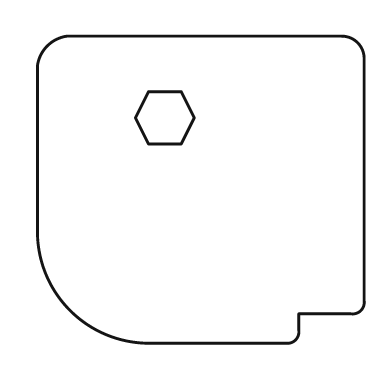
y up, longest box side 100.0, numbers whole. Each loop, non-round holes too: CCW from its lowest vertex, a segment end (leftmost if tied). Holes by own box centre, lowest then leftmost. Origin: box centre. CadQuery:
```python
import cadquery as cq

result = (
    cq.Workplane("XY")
    .moveTo(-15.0, -47.0)
    .lineTo(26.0, -47.0)
    .threePointArc((29.0, -46.0), (30.0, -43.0))
    .lineTo(30.0, -38.0)
    .lineTo(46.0, -38.0)
    .threePointArc((49.0, -37.0), (50.0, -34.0))
    .lineTo(50.0, 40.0)
    .threePointArc((48.0, 45.0), (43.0, 47.0))
    .lineTo(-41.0, 47.0)
    .threePointArc((-47.0, 44.0), (-50.0, 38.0))
    .lineTo(-50.0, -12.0)
    .threePointArc((-40.0, -37.0), (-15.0, -47.0))
    .close()
    .moveTo(-16.0, 14.0)
    .lineTo(-6.0, 14.0)
    .lineTo(-2.0, 22.0)
    .lineTo(-6.0, 30.0)
    .lineTo(-16.0, 30.0)
    .lineTo(-20.0, 22.0)
    .close()
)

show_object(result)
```